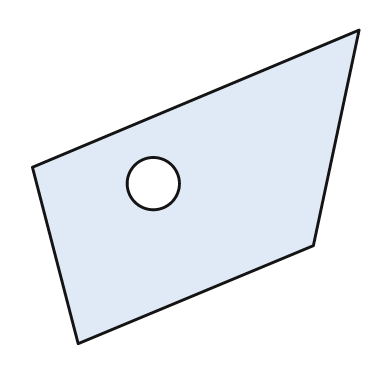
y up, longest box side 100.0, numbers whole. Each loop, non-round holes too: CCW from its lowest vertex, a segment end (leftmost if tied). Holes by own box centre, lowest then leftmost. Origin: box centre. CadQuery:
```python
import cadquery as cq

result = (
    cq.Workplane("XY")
    .moveTo(-36.0, -48.0)
    .lineTo(36.0, -18.0)
    .lineTo(50.0, 48.0)
    .lineTo(-50.0, 6.0)
    .close()
    .moveTo(-13.0, 1.0)
    .circle(8.0)
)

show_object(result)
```